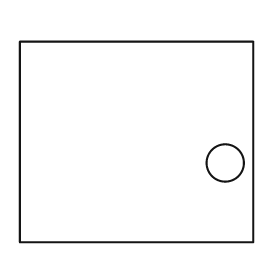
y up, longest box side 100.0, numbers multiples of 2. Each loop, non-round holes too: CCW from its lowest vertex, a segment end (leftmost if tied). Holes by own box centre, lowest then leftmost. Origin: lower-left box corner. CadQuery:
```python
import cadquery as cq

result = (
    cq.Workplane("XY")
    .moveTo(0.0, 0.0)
    .lineTo(100.0, 0.0)
    .lineTo(100.0, 86.0)
    .lineTo(0.0, 86.0)
    .close()
    .moveTo(88.0, 34.0)
    .circle(8.0)
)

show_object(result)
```